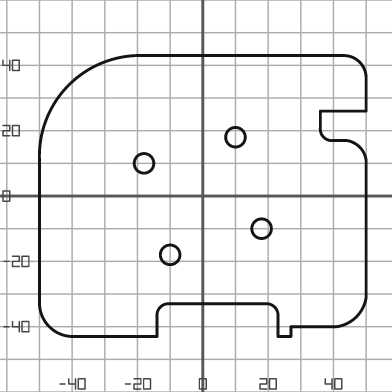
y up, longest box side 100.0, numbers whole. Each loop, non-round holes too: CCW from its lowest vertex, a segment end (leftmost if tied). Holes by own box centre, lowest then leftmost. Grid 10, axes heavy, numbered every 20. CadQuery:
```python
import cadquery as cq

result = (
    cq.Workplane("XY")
    .moveTo(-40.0, -43.0)
    .lineTo(-14.0, -43.0)
    .lineTo(-14.0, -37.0)
    .threePointArc((-13.0, -34.0), (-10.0, -33.0))
    .lineTo(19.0, -33.0)
    .threePointArc((22.0, -34.0), (23.0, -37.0))
    .lineTo(23.0, -43.0)
    .lineTo(27.0, -43.0)
    .lineTo(27.0, -40.0)
    .lineTo(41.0, -40.0)
    .threePointArc((47.0, -37.0), (50.0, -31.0))
    .lineTo(50.0, 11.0)
    .threePointArc((48.0, 15.0), (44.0, 17.0))
    .lineTo(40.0, 17.0)
    .threePointArc((37.0, 18.0), (36.0, 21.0))
    .lineTo(36.0, 26.0)
    .lineTo(50.0, 26.0)
    .lineTo(50.0, 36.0)
    .threePointArc((48.0, 41.0), (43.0, 43.0))
    .lineTo(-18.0, 43.0)
    .threePointArc((-41.0, 34.0), (-50.0, 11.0))
    .lineTo(-50.0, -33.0)
    .threePointArc((-47.0, -40.0), (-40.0, -43.0))
    .close()
    .moveTo(-10.0, -18.0)
    .circle(3.0)
    .moveTo(18.0, -10.0)
    .circle(3.0)
    .moveTo(-18.0, 10.0)
    .circle(3.0)
    .moveTo(10.0, 18.0)
    .circle(3.0)
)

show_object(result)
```